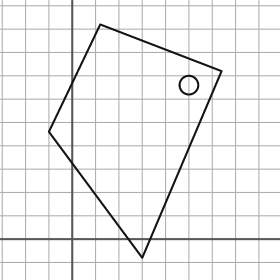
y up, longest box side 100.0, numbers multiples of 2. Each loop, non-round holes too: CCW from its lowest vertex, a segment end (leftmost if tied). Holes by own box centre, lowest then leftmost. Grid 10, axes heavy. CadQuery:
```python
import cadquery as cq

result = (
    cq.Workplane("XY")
    .moveTo(30.0, -8.0)
    .lineTo(64.0, 72.0)
    .lineTo(12.0, 92.0)
    .lineTo(-10.0, 46.0)
    .close()
    .moveTo(50.0, 66.0)
    .circle(4.0)
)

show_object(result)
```